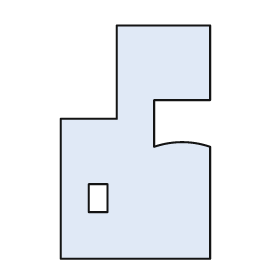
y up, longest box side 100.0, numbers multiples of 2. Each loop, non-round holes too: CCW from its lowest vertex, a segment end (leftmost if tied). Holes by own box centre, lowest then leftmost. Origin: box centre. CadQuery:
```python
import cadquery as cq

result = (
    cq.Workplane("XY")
    .moveTo(-32.0, -50.0)
    .lineTo(32.0, -50.0)
    .lineTo(32.0, -2.0)
    .threePointArc((20.0, 0.0), (8.0, -2.0))
    .lineTo(8.0, 18.0)
    .lineTo(32.0, 18.0)
    .lineTo(32.0, 50.0)
    .lineTo(-8.0, 50.0)
    .lineTo(-8.0, 10.0)
    .lineTo(-32.0, 10.0)
    .close()
    .moveTo(-20.0, -30.0)
    .lineTo(-12.0, -30.0)
    .lineTo(-12.0, -18.0)
    .lineTo(-20.0, -18.0)
    .close()
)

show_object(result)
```